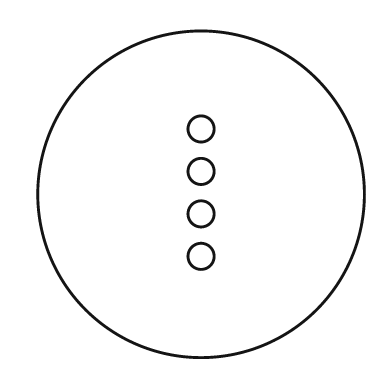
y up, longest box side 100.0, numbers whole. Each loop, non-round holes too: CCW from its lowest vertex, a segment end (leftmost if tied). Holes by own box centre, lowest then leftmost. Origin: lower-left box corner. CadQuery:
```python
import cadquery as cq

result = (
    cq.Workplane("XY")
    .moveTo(50.0, 50.0)
    .circle(50.0)
    .moveTo(50.0, 31.0)
    .circle(4.0)
    .moveTo(50.0, 44.0)
    .circle(4.0)
    .moveTo(50.0, 57.0)
    .circle(4.0)
    .moveTo(50.0, 70.0)
    .circle(4.0)
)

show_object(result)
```